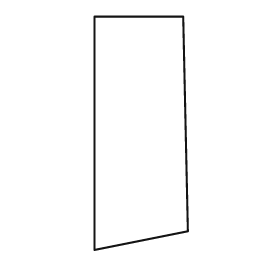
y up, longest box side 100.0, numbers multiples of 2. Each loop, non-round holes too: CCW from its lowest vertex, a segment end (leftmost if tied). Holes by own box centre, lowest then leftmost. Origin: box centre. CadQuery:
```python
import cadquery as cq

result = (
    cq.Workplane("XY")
    .moveTo(-20.0, -50.0)
    .lineTo(20.0, -42.0)
    .lineTo(18.0, 50.0)
    .lineTo(-20.0, 50.0)
    .close()
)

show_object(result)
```